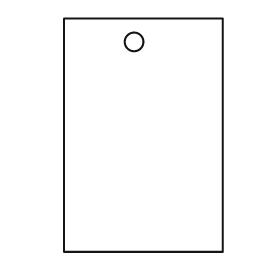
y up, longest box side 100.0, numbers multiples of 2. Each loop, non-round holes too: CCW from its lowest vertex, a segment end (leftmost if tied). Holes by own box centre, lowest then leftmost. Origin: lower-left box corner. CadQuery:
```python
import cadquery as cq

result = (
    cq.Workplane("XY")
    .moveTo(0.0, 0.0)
    .lineTo(68.0, 0.0)
    .lineTo(68.0, 100.0)
    .lineTo(0.0, 100.0)
    .close()
    .moveTo(30.0, 90.0)
    .circle(4.0)
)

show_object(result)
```